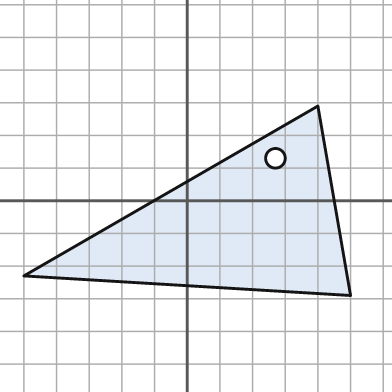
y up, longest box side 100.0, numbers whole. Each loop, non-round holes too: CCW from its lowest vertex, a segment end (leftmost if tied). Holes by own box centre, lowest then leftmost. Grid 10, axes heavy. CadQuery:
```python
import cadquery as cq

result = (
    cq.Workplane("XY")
    .moveTo(50.0, -29.0)
    .lineTo(40.0, 29.0)
    .lineTo(-50.0, -23.0)
    .close()
    .moveTo(27.0, 13.0)
    .circle(3.0)
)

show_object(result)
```